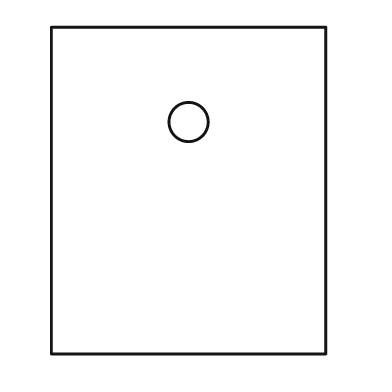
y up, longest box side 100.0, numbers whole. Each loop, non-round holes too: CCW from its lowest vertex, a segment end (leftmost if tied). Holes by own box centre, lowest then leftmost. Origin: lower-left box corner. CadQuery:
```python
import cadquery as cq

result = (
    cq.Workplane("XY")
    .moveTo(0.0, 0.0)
    .lineTo(84.0, 0.0)
    .lineTo(84.0, 100.0)
    .lineTo(0.0, 100.0)
    .close()
    .moveTo(42.0, 71.0)
    .circle(6.0)
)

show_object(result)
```